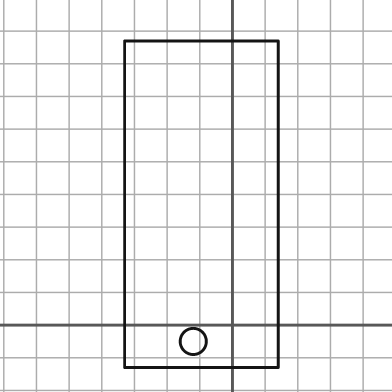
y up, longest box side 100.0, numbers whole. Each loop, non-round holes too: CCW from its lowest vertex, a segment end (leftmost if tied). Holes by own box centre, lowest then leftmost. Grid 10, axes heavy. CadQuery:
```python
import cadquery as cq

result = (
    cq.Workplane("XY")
    .moveTo(-33.0, -13.0)
    .lineTo(14.0, -13.0)
    .lineTo(14.0, 87.0)
    .lineTo(-33.0, 87.0)
    .close()
    .moveTo(-12.0, -5.0)
    .circle(4.0)
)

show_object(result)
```